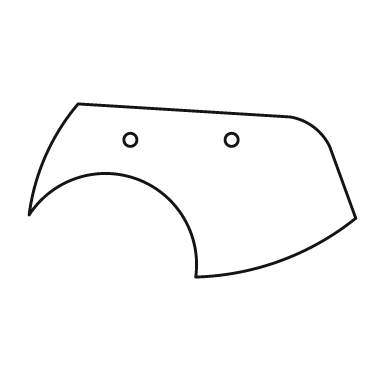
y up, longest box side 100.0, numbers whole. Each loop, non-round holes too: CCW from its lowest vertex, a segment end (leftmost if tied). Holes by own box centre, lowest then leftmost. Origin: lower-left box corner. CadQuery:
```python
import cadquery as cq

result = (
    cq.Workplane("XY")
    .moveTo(51.0, 0.0)
    .threePointArc((77.0, 5.0), (100.0, 18.0))
    .lineTo(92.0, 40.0)
    .threePointArc((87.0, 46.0), (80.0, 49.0))
    .lineTo(15.0, 53.0)
    .threePointArc((5.0, 37.0), (0.0, 19.0))
    .threePointArc((33.0, 30.0), (51.0, 0.0))
    .close()
    .moveTo(31.0, 42.0)
    .circle(2.0)
    .moveTo(62.0, 42.0)
    .circle(2.0)
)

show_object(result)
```